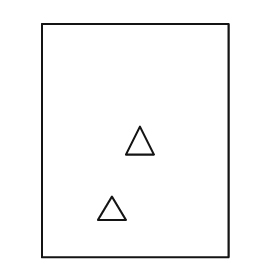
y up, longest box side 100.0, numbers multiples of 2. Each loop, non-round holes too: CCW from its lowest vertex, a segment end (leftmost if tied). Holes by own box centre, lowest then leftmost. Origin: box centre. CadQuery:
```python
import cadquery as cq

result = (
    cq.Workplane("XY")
    .moveTo(-40.0, -50.0)
    .lineTo(40.0, -50.0)
    .lineTo(40.0, 50.0)
    .lineTo(-40.0, 50.0)
    .close()
    .moveTo(-16.0, -34.0)
    .lineTo(-4.0, -34.0)
    .lineTo(-10.0, -24.0)
    .close()
    .moveTo(-4.0, -6.0)
    .lineTo(8.0, -6.0)
    .lineTo(2.0, 6.0)
    .close()
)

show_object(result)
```